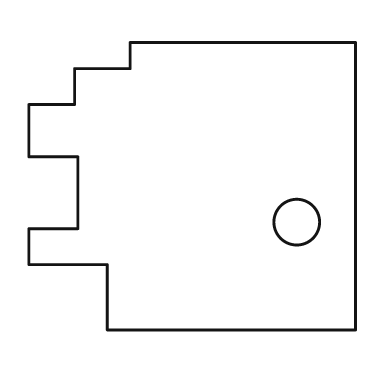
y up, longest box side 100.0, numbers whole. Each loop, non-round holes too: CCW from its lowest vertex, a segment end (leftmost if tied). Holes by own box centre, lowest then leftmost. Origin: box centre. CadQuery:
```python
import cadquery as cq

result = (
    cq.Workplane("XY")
    .moveTo(-26.0, -44.0)
    .lineTo(50.0, -44.0)
    .lineTo(50.0, 44.0)
    .lineTo(-19.0, 44.0)
    .lineTo(-19.0, 36.0)
    .lineTo(-36.0, 36.0)
    .lineTo(-36.0, 25.0)
    .lineTo(-50.0, 25.0)
    .lineTo(-50.0, 9.0)
    .lineTo(-35.0, 9.0)
    .lineTo(-35.0, -13.0)
    .lineTo(-50.0, -13.0)
    .lineTo(-50.0, -24.0)
    .lineTo(-26.0, -24.0)
    .close()
    .moveTo(32.0, -11.0)
    .circle(7.0)
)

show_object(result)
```